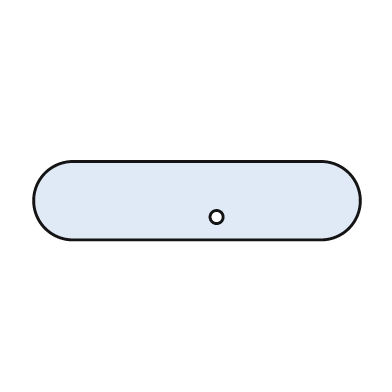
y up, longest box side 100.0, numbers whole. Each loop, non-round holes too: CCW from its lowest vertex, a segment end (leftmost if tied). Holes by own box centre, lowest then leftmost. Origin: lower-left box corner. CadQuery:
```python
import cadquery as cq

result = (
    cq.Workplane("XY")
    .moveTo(12.0, 0.0)
    .lineTo(88.0, 0.0)
    .threePointArc((100.0, 12.0), (88.0, 24.0))
    .lineTo(12.0, 24.0)
    .threePointArc((0.0, 12.0), (12.0, 0.0))
    .close()
    .moveTo(56.0, 7.0)
    .circle(2.0)
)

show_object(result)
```